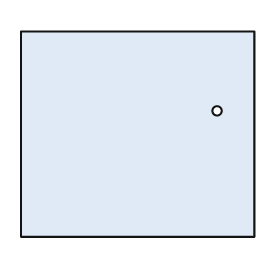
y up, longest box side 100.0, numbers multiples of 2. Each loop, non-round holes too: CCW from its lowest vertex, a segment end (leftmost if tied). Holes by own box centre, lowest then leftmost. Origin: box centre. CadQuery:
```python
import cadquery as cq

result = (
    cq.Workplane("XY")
    .moveTo(-50.0, -44.0)
    .lineTo(50.0, -44.0)
    .lineTo(50.0, 44.0)
    .lineTo(-50.0, 44.0)
    .close()
    .moveTo(34.0, 10.0)
    .circle(2.0)
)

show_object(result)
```